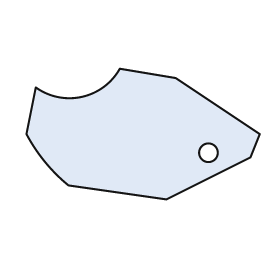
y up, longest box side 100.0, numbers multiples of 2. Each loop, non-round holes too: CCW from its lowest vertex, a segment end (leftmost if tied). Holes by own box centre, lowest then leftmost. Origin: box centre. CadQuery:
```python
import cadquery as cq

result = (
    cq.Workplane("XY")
    .moveTo(10.0, -28.0)
    .lineTo(46.0, -10.0)
    .lineTo(50.0, 0.0)
    .lineTo(14.0, 24.0)
    .lineTo(-10.0, 28.0)
    .threePointArc((-26.0, 16.0), (-46.0, 20.0))
    .lineTo(-50.0, 0.0)
    .threePointArc((-42.0, -12.0), (-32.0, -22.0))
    .close()
    .moveTo(28.0, -8.0)
    .circle(4.0)
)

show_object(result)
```